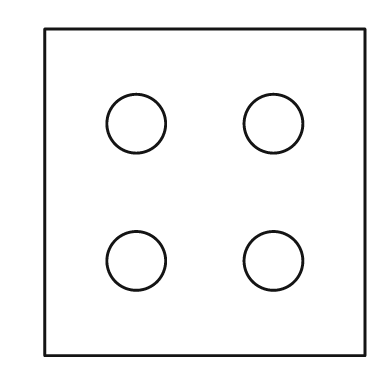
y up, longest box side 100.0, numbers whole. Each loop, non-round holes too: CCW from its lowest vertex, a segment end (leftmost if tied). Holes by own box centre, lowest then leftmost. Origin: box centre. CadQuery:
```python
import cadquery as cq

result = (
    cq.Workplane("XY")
    .moveTo(-49.0, -50.0)
    .lineTo(49.0, -50.0)
    .lineTo(49.0, 50.0)
    .lineTo(-49.0, 50.0)
    .close()
    .moveTo(-21.0, -21.0)
    .circle(9.0)
    .moveTo(21.0, -21.0)
    .circle(9.0)
    .moveTo(-21.0, 21.0)
    .circle(9.0)
    .moveTo(21.0, 21.0)
    .circle(9.0)
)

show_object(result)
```